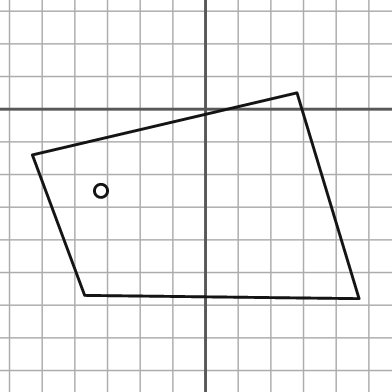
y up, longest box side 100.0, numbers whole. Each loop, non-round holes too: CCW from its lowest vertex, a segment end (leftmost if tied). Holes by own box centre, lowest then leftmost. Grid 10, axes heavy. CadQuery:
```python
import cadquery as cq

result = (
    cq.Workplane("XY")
    .moveTo(47.0, -58.0)
    .lineTo(28.0, 5.0)
    .lineTo(-53.0, -14.0)
    .lineTo(-37.0, -57.0)
    .close()
    .moveTo(-32.0, -25.0)
    .circle(2.0)
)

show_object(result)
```